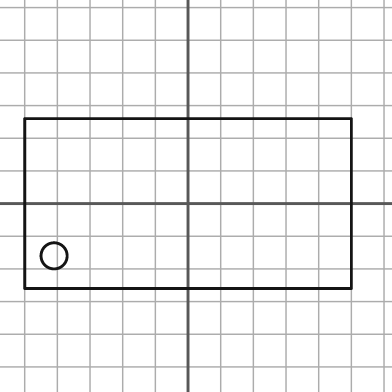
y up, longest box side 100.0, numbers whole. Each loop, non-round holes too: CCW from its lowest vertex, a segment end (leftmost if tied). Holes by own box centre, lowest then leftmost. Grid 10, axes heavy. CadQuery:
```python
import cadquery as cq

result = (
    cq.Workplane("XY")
    .moveTo(-50.0, -26.0)
    .lineTo(50.0, -26.0)
    .lineTo(50.0, 26.0)
    .lineTo(-50.0, 26.0)
    .close()
    .moveTo(-41.0, -16.0)
    .circle(4.0)
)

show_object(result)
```